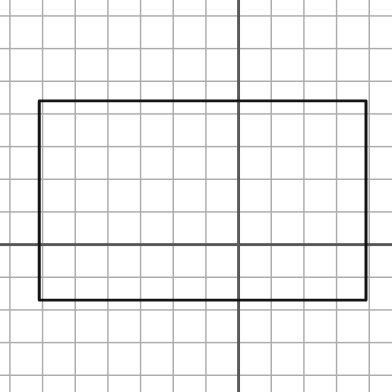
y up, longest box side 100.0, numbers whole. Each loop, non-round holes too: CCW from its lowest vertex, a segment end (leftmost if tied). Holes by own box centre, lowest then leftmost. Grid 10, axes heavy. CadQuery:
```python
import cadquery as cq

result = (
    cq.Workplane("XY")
    .moveTo(-61.0, -17.0)
    .lineTo(39.0, -17.0)
    .lineTo(39.0, 44.0)
    .lineTo(-61.0, 44.0)
    .close()
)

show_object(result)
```